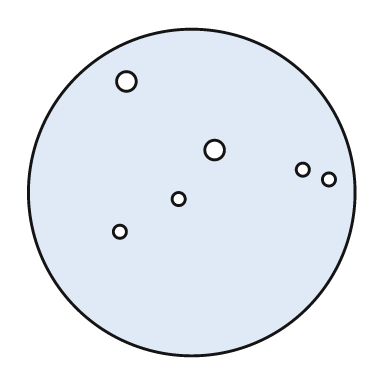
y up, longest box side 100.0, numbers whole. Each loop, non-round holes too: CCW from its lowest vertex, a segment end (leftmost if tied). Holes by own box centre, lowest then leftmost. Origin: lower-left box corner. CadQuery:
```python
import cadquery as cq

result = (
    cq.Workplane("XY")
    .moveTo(50.0, 50.0)
    .circle(50.0)
    .moveTo(28.0, 38.0)
    .circle(2.0)
    .moveTo(46.0, 48.0)
    .circle(2.0)
    .moveTo(92.0, 54.0)
    .circle(2.0)
    .moveTo(84.0, 57.0)
    .circle(2.0)
    .moveTo(57.0, 63.0)
    .circle(3.0)
    .moveTo(30.0, 84.0)
    .circle(3.0)
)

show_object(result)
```